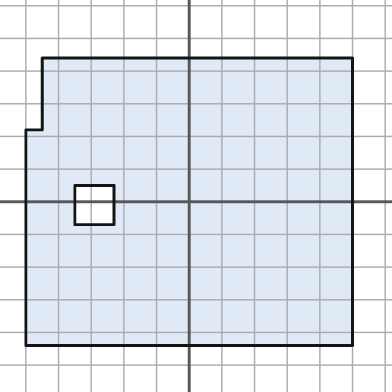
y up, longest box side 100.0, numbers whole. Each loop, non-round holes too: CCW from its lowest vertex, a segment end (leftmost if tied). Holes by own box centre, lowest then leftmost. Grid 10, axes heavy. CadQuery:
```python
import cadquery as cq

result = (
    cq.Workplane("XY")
    .moveTo(-50.0, -44.0)
    .lineTo(50.0, -44.0)
    .lineTo(50.0, 44.0)
    .lineTo(-45.0, 44.0)
    .lineTo(-45.0, 22.0)
    .lineTo(-50.0, 22.0)
    .close()
    .moveTo(-35.0, -7.0)
    .lineTo(-23.0, -7.0)
    .lineTo(-23.0, 5.0)
    .lineTo(-35.0, 5.0)
    .close()
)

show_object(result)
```